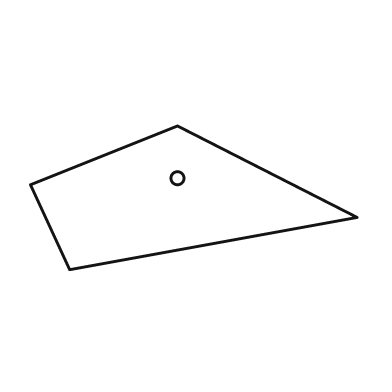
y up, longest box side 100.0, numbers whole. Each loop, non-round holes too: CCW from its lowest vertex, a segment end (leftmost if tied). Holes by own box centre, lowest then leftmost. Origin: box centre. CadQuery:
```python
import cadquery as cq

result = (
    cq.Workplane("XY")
    .moveTo(-38.0, -22.0)
    .lineTo(50.0, -6.0)
    .lineTo(-5.0, 22.0)
    .lineTo(-50.0, 4.0)
    .close()
    .moveTo(-5.0, 6.0)
    .circle(2.0)
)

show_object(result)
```